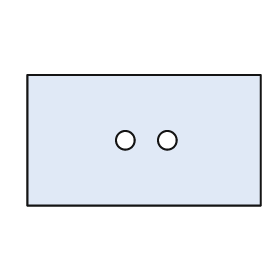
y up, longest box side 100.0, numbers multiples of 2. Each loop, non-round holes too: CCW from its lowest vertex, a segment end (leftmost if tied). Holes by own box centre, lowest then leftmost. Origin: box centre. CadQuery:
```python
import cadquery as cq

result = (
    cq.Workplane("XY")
    .moveTo(-50.0, -28.0)
    .lineTo(50.0, -28.0)
    .lineTo(50.0, 28.0)
    .lineTo(-50.0, 28.0)
    .close()
    .moveTo(-8.0, 0.0)
    .circle(4.0)
    .moveTo(10.0, 0.0)
    .circle(4.0)
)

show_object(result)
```